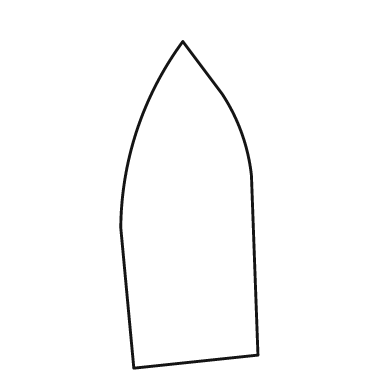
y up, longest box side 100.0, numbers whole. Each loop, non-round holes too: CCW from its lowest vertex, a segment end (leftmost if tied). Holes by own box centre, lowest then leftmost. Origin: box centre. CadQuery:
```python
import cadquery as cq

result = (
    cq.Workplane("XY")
    .moveTo(-17.0, -50.0)
    .lineTo(21.0, -46.0)
    .lineTo(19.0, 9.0)
    .threePointArc((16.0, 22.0), (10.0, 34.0))
    .lineTo(-2.0, 50.0)
    .threePointArc((-16.0, 23.0), (-21.0, -7.0))
    .close()
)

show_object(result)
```